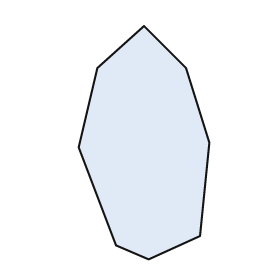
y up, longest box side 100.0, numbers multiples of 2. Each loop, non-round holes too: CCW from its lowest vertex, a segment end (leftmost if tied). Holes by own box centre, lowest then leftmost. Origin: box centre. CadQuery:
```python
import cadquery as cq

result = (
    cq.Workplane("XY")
    .moveTo(2.0, -50.0)
    .lineTo(24.0, -40.0)
    .lineTo(28.0, 0.0)
    .lineTo(18.0, 32.0)
    .lineTo(0.0, 50.0)
    .lineTo(-20.0, 32.0)
    .lineTo(-28.0, -2.0)
    .lineTo(-12.0, -44.0)
    .close()
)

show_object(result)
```